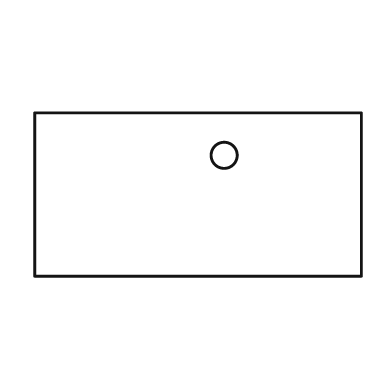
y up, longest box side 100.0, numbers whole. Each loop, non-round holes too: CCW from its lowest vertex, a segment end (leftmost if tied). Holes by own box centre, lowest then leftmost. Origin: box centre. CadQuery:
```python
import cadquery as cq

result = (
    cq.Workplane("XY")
    .moveTo(-50.0, -25.0)
    .lineTo(50.0, -25.0)
    .lineTo(50.0, 25.0)
    .lineTo(-50.0, 25.0)
    .close()
    .moveTo(8.0, 12.0)
    .circle(4.0)
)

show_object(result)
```